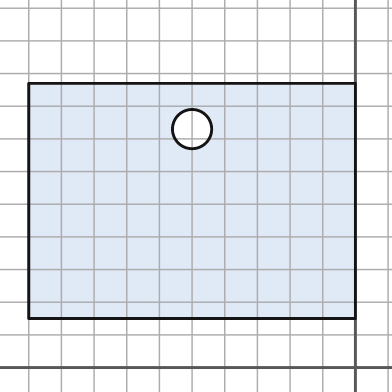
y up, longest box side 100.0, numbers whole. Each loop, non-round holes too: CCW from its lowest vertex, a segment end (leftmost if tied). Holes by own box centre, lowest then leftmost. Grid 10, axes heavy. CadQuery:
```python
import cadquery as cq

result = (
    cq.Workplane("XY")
    .moveTo(-100.0, 15.0)
    .lineTo(0.0, 15.0)
    .lineTo(0.0, 87.0)
    .lineTo(-100.0, 87.0)
    .close()
    .moveTo(-50.0, 73.0)
    .circle(6.0)
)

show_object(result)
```